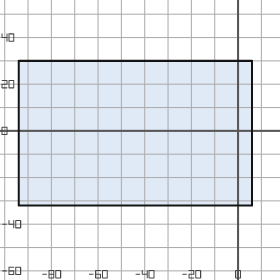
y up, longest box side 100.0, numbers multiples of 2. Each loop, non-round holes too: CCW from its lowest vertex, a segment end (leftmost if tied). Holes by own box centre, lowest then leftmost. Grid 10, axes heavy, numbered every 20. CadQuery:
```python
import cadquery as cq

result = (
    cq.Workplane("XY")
    .moveTo(-94.0, -32.0)
    .lineTo(6.0, -32.0)
    .lineTo(6.0, 30.0)
    .lineTo(-94.0, 30.0)
    .close()
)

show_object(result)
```